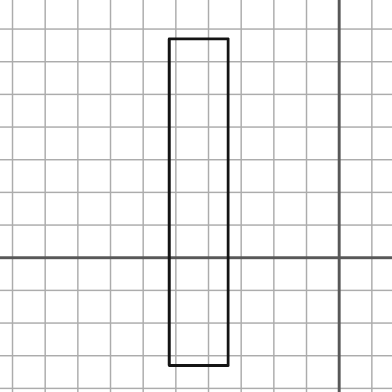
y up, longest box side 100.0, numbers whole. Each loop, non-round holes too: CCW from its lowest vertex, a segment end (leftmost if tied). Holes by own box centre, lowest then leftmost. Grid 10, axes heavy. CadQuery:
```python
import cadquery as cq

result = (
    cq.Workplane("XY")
    .moveTo(-52.0, -33.0)
    .lineTo(-34.0, -33.0)
    .lineTo(-34.0, 67.0)
    .lineTo(-52.0, 67.0)
    .close()
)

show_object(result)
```